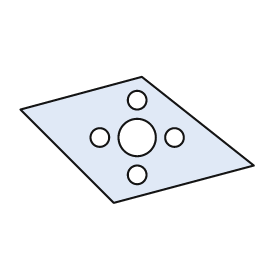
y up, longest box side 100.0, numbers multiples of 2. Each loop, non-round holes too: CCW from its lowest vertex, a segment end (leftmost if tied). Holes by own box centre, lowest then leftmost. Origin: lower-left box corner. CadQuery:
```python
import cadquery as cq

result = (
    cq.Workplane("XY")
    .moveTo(40.0, 0.0)
    .lineTo(100.0, 16.0)
    .lineTo(52.0, 54.0)
    .lineTo(0.0, 40.0)
    .close()
    .moveTo(50.0, 12.0)
    .circle(4.0)
    .moveTo(34.0, 28.0)
    .circle(4.0)
    .moveTo(50.0, 28.0)
    .circle(8.0)
    .moveTo(66.0, 28.0)
    .circle(4.0)
    .moveTo(50.0, 44.0)
    .circle(4.0)
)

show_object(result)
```